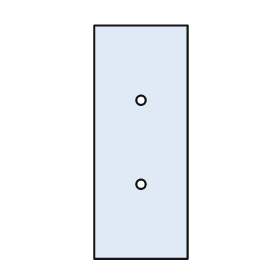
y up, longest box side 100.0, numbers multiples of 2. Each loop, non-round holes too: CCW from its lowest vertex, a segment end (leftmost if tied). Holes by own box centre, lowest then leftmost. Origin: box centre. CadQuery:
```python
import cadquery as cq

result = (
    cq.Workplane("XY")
    .moveTo(-20.0, -50.0)
    .lineTo(20.0, -50.0)
    .lineTo(20.0, 50.0)
    .lineTo(-20.0, 50.0)
    .close()
    .moveTo(0.0, -18.0)
    .circle(2.0)
    .moveTo(0.0, 18.0)
    .circle(2.0)
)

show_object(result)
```